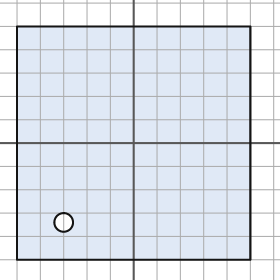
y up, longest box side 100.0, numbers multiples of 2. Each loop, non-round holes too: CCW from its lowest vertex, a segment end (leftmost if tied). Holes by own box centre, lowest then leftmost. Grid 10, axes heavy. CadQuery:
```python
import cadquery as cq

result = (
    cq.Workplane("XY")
    .moveTo(-50.0, -50.0)
    .lineTo(50.0, -50.0)
    .lineTo(50.0, 50.0)
    .lineTo(-50.0, 50.0)
    .close()
    .moveTo(-30.0, -34.0)
    .circle(4.0)
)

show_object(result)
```